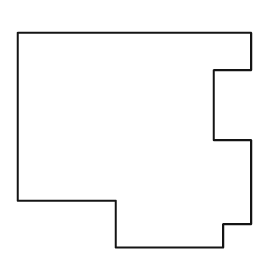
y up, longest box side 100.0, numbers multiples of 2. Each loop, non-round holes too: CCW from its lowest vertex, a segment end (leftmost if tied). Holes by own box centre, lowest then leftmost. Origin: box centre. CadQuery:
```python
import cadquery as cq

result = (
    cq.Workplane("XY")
    .moveTo(-8.0, -46.0)
    .lineTo(38.0, -46.0)
    .lineTo(38.0, -36.0)
    .lineTo(50.0, -36.0)
    .lineTo(50.0, 0.0)
    .lineTo(34.0, 0.0)
    .lineTo(34.0, 30.0)
    .lineTo(50.0, 30.0)
    .lineTo(50.0, 46.0)
    .lineTo(-50.0, 46.0)
    .lineTo(-50.0, -26.0)
    .lineTo(-8.0, -26.0)
    .close()
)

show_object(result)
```